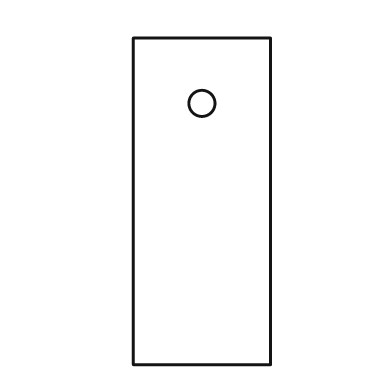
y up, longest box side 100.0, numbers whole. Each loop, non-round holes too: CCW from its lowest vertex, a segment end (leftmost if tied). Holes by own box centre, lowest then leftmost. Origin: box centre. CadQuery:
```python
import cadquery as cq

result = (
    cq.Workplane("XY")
    .moveTo(-21.0, -50.0)
    .lineTo(21.0, -50.0)
    .lineTo(21.0, 50.0)
    .lineTo(-21.0, 50.0)
    .close()
    .moveTo(0.0, 30.0)
    .circle(4.0)
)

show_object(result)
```